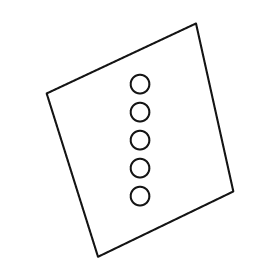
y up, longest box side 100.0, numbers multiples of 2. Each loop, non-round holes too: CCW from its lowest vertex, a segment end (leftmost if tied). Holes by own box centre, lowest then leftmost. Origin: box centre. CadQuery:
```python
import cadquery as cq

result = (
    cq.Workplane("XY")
    .moveTo(-18.0, -50.0)
    .lineTo(40.0, -22.0)
    .lineTo(24.0, 50.0)
    .lineTo(-40.0, 20.0)
    .close()
    .moveTo(0.0, -24.0)
    .circle(4.0)
    .moveTo(0.0, -12.0)
    .circle(4.0)
    .moveTo(0.0, 0.0)
    .circle(4.0)
    .moveTo(0.0, 12.0)
    .circle(4.0)
    .moveTo(0.0, 24.0)
    .circle(4.0)
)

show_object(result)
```